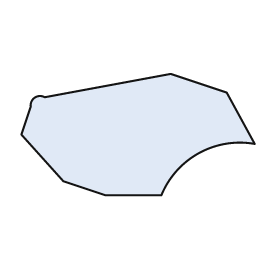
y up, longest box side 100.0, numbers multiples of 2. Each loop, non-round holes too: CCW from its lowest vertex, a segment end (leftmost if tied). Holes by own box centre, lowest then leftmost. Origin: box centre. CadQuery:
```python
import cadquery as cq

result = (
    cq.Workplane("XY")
    .moveTo(-14.0, -26.0)
    .lineTo(10.0, -26.0)
    .threePointArc((26.0, -8.0), (50.0, -4.0))
    .lineTo(38.0, 18.0)
    .lineTo(14.0, 26.0)
    .lineTo(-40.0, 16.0)
    .threePointArc((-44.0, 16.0), (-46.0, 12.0))
    .lineTo(-50.0, 0.0)
    .lineTo(-32.0, -20.0)
    .close()
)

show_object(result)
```